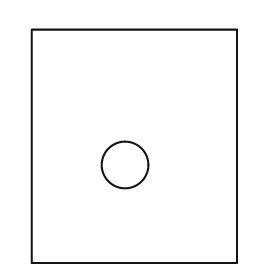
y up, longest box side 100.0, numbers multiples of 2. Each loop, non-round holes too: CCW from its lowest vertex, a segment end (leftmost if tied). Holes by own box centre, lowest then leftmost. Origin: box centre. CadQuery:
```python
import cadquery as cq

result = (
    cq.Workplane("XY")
    .moveTo(-44.0, -50.0)
    .lineTo(44.0, -50.0)
    .lineTo(44.0, 50.0)
    .lineTo(-44.0, 50.0)
    .close()
    .moveTo(-4.0, -8.0)
    .circle(10.0)
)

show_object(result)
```